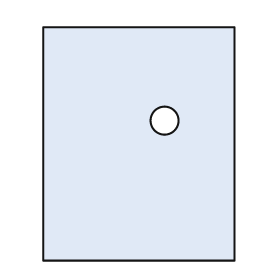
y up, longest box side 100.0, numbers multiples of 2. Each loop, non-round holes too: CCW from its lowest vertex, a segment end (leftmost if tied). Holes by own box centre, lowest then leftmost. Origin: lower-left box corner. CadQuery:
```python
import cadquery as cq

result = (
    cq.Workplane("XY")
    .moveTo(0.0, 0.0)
    .lineTo(82.0, 0.0)
    .lineTo(82.0, 100.0)
    .lineTo(0.0, 100.0)
    .close()
    .moveTo(52.0, 60.0)
    .circle(6.0)
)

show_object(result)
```